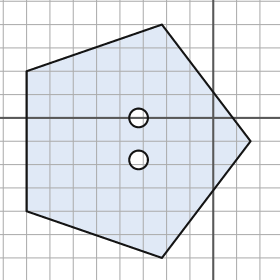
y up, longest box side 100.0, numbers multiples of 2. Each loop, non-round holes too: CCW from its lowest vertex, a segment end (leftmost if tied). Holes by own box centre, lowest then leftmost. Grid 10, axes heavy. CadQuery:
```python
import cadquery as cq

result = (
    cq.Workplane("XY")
    .moveTo(-22.0, -60.0)
    .lineTo(16.0, -10.0)
    .lineTo(-22.0, 40.0)
    .lineTo(-80.0, 20.0)
    .lineTo(-80.0, -40.0)
    .close()
    .moveTo(-32.0, -18.0)
    .circle(4.0)
    .moveTo(-32.0, 0.0)
    .circle(4.0)
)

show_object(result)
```